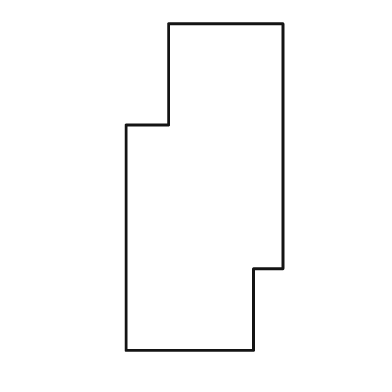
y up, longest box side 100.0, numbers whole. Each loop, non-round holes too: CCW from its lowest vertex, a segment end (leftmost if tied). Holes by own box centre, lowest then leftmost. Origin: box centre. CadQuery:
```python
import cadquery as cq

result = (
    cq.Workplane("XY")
    .moveTo(-24.0, -50.0)
    .lineTo(15.0, -50.0)
    .lineTo(15.0, -25.0)
    .lineTo(24.0, -25.0)
    .lineTo(24.0, 50.0)
    .lineTo(-11.0, 50.0)
    .lineTo(-11.0, 19.0)
    .lineTo(-24.0, 19.0)
    .close()
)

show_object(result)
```